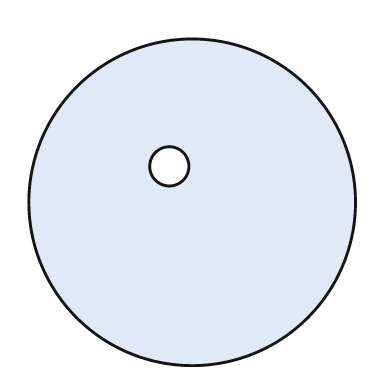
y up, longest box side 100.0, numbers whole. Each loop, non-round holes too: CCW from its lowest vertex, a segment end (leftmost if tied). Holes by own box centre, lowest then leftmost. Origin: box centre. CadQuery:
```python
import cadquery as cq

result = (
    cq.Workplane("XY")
    .moveTo(0.0, 0.0)
    .circle(50.0)
    .moveTo(-7.0, 11.0)
    .circle(6.0)
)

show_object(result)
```